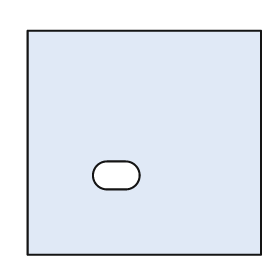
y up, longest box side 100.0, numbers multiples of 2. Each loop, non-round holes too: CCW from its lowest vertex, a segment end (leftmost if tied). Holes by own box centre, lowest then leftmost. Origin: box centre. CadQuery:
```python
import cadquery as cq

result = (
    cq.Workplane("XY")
    .moveTo(-50.0, -48.0)
    .lineTo(50.0, -48.0)
    .lineTo(50.0, 48.0)
    .lineTo(-50.0, 48.0)
    .close()
    .moveTo(-16.0, -20.0)
    .lineTo(-8.0, -20.0)
    .threePointArc((-2.0, -14.0), (-8.0, -8.0))
    .lineTo(-16.0, -8.0)
    .threePointArc((-22.0, -14.0), (-16.0, -20.0))
    .close()
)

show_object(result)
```